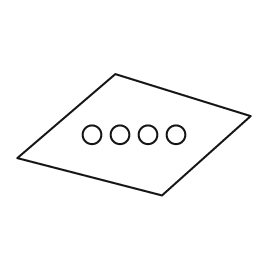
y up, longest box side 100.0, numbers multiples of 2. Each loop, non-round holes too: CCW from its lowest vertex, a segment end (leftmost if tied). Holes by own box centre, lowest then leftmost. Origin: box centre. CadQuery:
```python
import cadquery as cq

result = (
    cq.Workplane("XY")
    .moveTo(12.0, -26.0)
    .lineTo(50.0, 8.0)
    .lineTo(-8.0, 26.0)
    .lineTo(-50.0, -10.0)
    .close()
    .moveTo(-18.0, 0.0)
    .circle(4.0)
    .moveTo(-6.0, 0.0)
    .circle(4.0)
    .moveTo(6.0, 0.0)
    .circle(4.0)
    .moveTo(18.0, 0.0)
    .circle(4.0)
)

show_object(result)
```